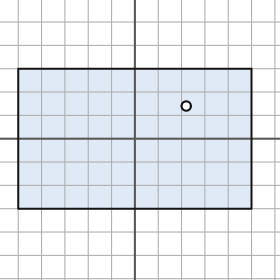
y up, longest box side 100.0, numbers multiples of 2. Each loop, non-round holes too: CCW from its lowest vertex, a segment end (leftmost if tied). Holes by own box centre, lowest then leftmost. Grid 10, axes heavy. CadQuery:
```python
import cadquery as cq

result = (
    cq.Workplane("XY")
    .moveTo(-50.0, -30.0)
    .lineTo(50.0, -30.0)
    .lineTo(50.0, 30.0)
    .lineTo(-50.0, 30.0)
    .close()
    .moveTo(22.0, 14.0)
    .circle(2.0)
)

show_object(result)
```